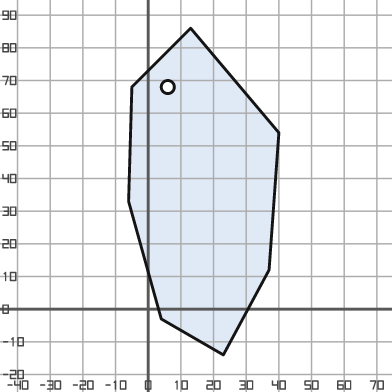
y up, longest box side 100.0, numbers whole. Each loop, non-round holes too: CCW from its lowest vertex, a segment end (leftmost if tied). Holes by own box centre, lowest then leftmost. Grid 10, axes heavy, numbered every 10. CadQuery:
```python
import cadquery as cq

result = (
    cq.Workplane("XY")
    .moveTo(23.0, -14.0)
    .lineTo(37.0, 12.0)
    .lineTo(40.0, 54.0)
    .lineTo(13.0, 86.0)
    .lineTo(-5.0, 68.0)
    .lineTo(-6.0, 33.0)
    .lineTo(4.0, -3.0)
    .close()
    .moveTo(6.0, 68.0)
    .circle(2.0)
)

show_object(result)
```